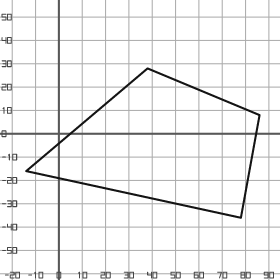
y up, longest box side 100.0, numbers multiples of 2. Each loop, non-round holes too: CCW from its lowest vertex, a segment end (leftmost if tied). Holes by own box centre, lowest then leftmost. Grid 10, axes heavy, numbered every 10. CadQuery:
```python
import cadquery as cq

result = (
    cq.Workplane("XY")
    .moveTo(78.0, -36.0)
    .lineTo(86.0, 8.0)
    .lineTo(38.0, 28.0)
    .lineTo(-14.0, -16.0)
    .close()
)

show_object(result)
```